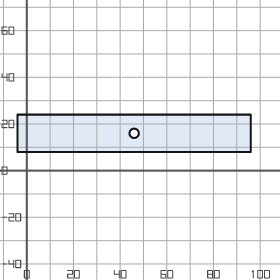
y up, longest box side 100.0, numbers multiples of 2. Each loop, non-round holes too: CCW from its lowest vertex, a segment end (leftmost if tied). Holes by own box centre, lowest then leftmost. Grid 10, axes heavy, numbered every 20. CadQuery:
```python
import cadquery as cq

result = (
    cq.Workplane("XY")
    .moveTo(-4.0, 8.0)
    .lineTo(96.0, 8.0)
    .lineTo(96.0, 24.0)
    .lineTo(-4.0, 24.0)
    .close()
    .moveTo(46.0, 16.0)
    .circle(2.0)
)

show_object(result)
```